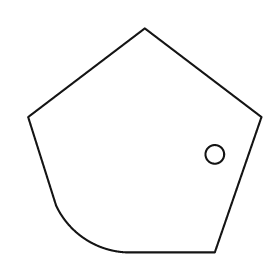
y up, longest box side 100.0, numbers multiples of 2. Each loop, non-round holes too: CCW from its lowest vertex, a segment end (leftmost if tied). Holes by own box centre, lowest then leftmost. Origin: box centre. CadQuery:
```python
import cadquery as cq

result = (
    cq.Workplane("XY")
    .moveTo(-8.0, -48.0)
    .lineTo(30.0, -48.0)
    .lineTo(50.0, 10.0)
    .lineTo(0.0, 48.0)
    .lineTo(-50.0, 10.0)
    .lineTo(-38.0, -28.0)
    .threePointArc((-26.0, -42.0), (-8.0, -48.0))
    .close()
    .moveTo(30.0, -6.0)
    .circle(4.0)
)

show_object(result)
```